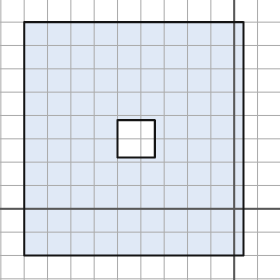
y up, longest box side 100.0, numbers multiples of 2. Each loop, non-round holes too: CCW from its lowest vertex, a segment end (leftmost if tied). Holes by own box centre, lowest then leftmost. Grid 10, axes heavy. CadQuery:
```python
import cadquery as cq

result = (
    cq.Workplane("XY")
    .moveTo(-90.0, -20.0)
    .lineTo(4.0, -20.0)
    .lineTo(4.0, 80.0)
    .lineTo(-90.0, 80.0)
    .close()
    .moveTo(-50.0, 22.0)
    .lineTo(-34.0, 22.0)
    .lineTo(-34.0, 38.0)
    .lineTo(-50.0, 38.0)
    .close()
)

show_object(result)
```